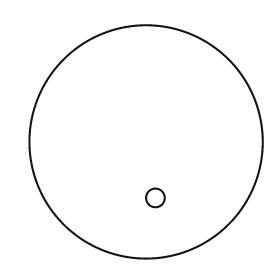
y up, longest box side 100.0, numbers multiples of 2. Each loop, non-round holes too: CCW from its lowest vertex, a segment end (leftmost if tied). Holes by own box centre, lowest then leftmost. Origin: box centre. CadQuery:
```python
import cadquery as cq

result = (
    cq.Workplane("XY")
    .moveTo(0.0, 0.0)
    .circle(50.0)
    .moveTo(4.0, -24.0)
    .circle(4.0)
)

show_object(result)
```